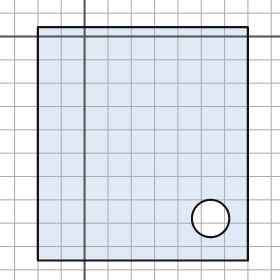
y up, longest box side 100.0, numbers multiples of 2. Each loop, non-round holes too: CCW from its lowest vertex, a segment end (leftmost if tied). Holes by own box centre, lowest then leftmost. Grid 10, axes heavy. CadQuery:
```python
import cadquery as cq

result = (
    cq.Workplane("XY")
    .moveTo(-20.0, -96.0)
    .lineTo(70.0, -96.0)
    .lineTo(70.0, 4.0)
    .lineTo(-20.0, 4.0)
    .close()
    .moveTo(54.0, -78.0)
    .circle(8.0)
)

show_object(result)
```